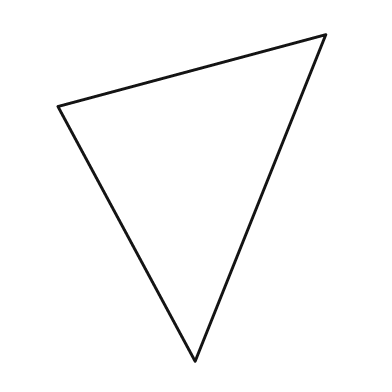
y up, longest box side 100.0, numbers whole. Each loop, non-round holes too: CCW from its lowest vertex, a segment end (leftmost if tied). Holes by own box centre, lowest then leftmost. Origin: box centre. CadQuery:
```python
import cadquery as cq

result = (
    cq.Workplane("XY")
    .moveTo(1.0, -50.0)
    .lineTo(41.0, 50.0)
    .lineTo(-41.0, 28.0)
    .close()
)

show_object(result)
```